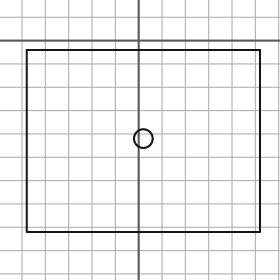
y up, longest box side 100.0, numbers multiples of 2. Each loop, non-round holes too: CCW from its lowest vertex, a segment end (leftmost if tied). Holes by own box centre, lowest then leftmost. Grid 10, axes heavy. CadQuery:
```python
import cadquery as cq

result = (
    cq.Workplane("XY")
    .moveTo(-48.0, -82.0)
    .lineTo(52.0, -82.0)
    .lineTo(52.0, -4.0)
    .lineTo(-48.0, -4.0)
    .close()
    .moveTo(2.0, -42.0)
    .circle(4.0)
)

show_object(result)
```